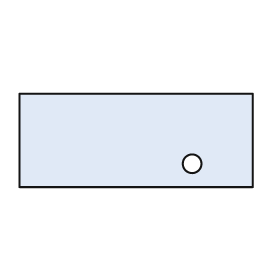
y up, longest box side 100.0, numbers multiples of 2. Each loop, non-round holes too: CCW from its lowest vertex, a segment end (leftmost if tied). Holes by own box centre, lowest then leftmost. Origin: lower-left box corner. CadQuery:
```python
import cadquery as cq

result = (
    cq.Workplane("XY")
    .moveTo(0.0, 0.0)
    .lineTo(100.0, 0.0)
    .lineTo(100.0, 40.0)
    .lineTo(0.0, 40.0)
    .close()
    .moveTo(74.0, 10.0)
    .circle(4.0)
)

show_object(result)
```